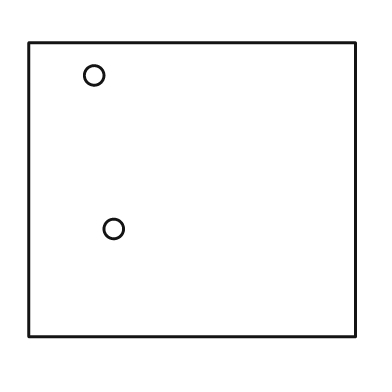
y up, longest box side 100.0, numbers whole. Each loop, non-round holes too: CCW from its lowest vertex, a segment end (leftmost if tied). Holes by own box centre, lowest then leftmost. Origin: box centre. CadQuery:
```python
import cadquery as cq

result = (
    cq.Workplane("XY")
    .moveTo(-50.0, -45.0)
    .lineTo(50.0, -45.0)
    .lineTo(50.0, 45.0)
    .lineTo(-50.0, 45.0)
    .close()
    .moveTo(-24.0, -12.0)
    .circle(3.0)
    .moveTo(-30.0, 35.0)
    .circle(3.0)
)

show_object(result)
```